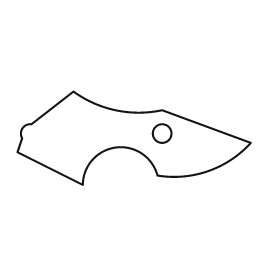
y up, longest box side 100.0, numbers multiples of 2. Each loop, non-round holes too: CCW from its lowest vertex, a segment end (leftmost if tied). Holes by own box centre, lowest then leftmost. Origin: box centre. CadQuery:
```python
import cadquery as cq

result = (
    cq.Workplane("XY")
    .moveTo(-22.0, -20.0)
    .threePointArc((-8.0, -4.0), (10.0, -16.0))
    .threePointArc((32.0, -14.0), (50.0, -2.0))
    .lineTo(12.0, 12.0)
    .threePointArc((-8.0, 12.0), (-26.0, 20.0))
    .lineTo(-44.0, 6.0)
    .threePointArc((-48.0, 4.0), (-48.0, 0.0))
    .lineTo(-50.0, -6.0)
    .close()
    .moveTo(12.0, 2.0)
    .circle(4.0)
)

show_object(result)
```